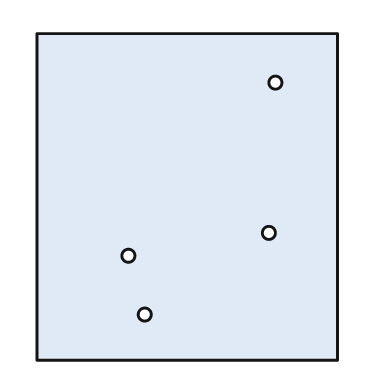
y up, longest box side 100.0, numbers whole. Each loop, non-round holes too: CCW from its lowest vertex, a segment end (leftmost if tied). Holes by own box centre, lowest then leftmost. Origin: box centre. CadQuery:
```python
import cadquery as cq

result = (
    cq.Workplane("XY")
    .moveTo(-46.0, -50.0)
    .lineTo(46.0, -50.0)
    .lineTo(46.0, 50.0)
    .lineTo(-46.0, 50.0)
    .close()
    .moveTo(-13.0, -36.0)
    .circle(2.0)
    .moveTo(-18.0, -18.0)
    .circle(2.0)
    .moveTo(25.0, -11.0)
    .circle(2.0)
    .moveTo(27.0, 35.0)
    .circle(2.0)
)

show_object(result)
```